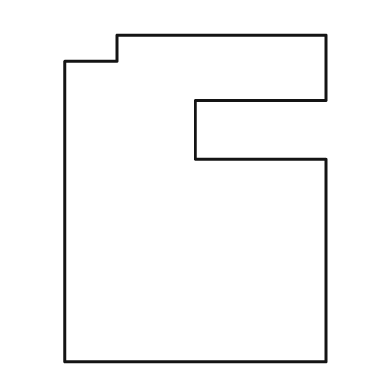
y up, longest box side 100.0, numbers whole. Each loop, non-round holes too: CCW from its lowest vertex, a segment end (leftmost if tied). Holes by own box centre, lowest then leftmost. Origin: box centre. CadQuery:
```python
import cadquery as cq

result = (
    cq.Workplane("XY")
    .moveTo(-40.0, -50.0)
    .lineTo(40.0, -50.0)
    .lineTo(40.0, 12.0)
    .lineTo(0.0, 12.0)
    .lineTo(0.0, 30.0)
    .lineTo(40.0, 30.0)
    .lineTo(40.0, 50.0)
    .lineTo(-24.0, 50.0)
    .lineTo(-24.0, 42.0)
    .lineTo(-40.0, 42.0)
    .close()
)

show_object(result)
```